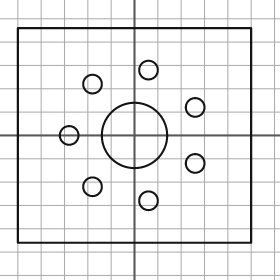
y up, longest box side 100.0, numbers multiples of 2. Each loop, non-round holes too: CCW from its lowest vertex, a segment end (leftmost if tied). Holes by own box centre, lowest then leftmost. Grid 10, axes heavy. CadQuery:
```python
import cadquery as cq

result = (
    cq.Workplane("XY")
    .moveTo(-50.0, -46.0)
    .lineTo(50.0, -46.0)
    .lineTo(50.0, 46.0)
    .lineTo(-50.0, 46.0)
    .close()
    .moveTo(6.0, -28.0)
    .circle(4.0)
    .moveTo(-18.0, -22.0)
    .circle(4.0)
    .moveTo(26.0, -12.0)
    .circle(4.0)
    .moveTo(-28.0, 0.0)
    .circle(4.0)
    .moveTo(0.0, 0.0)
    .circle(14.0)
    .moveTo(26.0, 12.0)
    .circle(4.0)
    .moveTo(-18.0, 22.0)
    .circle(4.0)
    .moveTo(6.0, 28.0)
    .circle(4.0)
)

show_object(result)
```